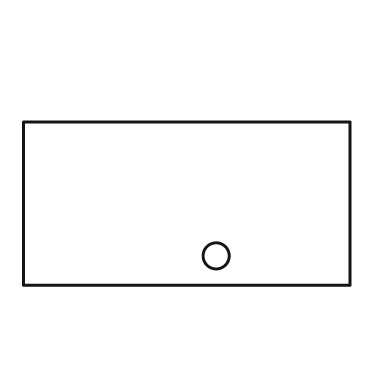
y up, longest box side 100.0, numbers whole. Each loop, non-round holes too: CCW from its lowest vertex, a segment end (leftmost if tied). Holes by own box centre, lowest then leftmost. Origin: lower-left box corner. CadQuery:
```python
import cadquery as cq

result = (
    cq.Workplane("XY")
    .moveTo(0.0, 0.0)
    .lineTo(100.0, 0.0)
    .lineTo(100.0, 50.0)
    .lineTo(0.0, 50.0)
    .close()
    .moveTo(59.0, 9.0)
    .circle(4.0)
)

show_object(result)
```